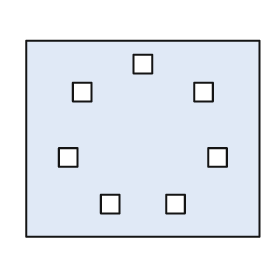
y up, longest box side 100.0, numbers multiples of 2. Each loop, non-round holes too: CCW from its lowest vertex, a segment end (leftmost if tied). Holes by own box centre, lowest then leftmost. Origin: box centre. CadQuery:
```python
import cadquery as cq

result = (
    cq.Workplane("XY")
    .moveTo(-50.0, -42.0)
    .lineTo(50.0, -42.0)
    .lineTo(50.0, 42.0)
    .lineTo(-50.0, 42.0)
    .close()
    .moveTo(-18.0, -32.0)
    .lineTo(-10.0, -32.0)
    .lineTo(-10.0, -24.0)
    .lineTo(-18.0, -24.0)
    .close()
    .moveTo(10.0, -32.0)
    .lineTo(18.0, -32.0)
    .lineTo(18.0, -24.0)
    .lineTo(10.0, -24.0)
    .close()
    .moveTo(-36.0, -12.0)
    .lineTo(-28.0, -12.0)
    .lineTo(-28.0, -4.0)
    .lineTo(-36.0, -4.0)
    .close()
    .moveTo(28.0, -12.0)
    .lineTo(36.0, -12.0)
    .lineTo(36.0, -4.0)
    .lineTo(28.0, -4.0)
    .close()
    .moveTo(-30.0, 16.0)
    .lineTo(-22.0, 16.0)
    .lineTo(-22.0, 24.0)
    .lineTo(-30.0, 24.0)
    .close()
    .moveTo(22.0, 16.0)
    .lineTo(30.0, 16.0)
    .lineTo(30.0, 24.0)
    .lineTo(22.0, 24.0)
    .close()
    .moveTo(-4.0, 28.0)
    .lineTo(4.0, 28.0)
    .lineTo(4.0, 36.0)
    .lineTo(-4.0, 36.0)
    .close()
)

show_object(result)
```